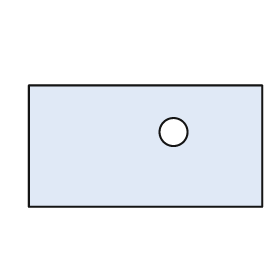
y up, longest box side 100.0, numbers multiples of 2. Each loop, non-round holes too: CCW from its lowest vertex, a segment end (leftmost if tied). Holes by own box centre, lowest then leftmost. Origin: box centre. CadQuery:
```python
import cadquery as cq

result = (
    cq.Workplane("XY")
    .moveTo(-50.0, -26.0)
    .lineTo(50.0, -26.0)
    .lineTo(50.0, 26.0)
    .lineTo(-50.0, 26.0)
    .close()
    .moveTo(12.0, 6.0)
    .circle(6.0)
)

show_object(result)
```